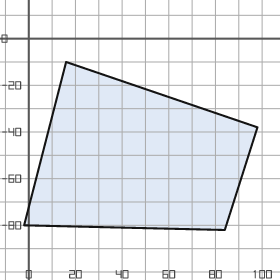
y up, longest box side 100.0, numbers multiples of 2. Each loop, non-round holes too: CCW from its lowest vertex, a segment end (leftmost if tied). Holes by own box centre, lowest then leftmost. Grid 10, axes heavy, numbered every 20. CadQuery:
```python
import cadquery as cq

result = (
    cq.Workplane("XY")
    .moveTo(84.0, -82.0)
    .lineTo(98.0, -38.0)
    .lineTo(16.0, -10.0)
    .lineTo(-2.0, -80.0)
    .close()
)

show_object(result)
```